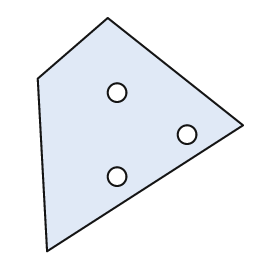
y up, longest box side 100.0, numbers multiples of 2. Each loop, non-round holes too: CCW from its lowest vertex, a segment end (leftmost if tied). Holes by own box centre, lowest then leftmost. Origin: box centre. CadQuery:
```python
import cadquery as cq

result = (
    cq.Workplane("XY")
    .moveTo(-40.0, -50.0)
    .lineTo(44.0, 4.0)
    .lineTo(-14.0, 50.0)
    .lineTo(-44.0, 24.0)
    .close()
    .moveTo(-10.0, -18.0)
    .circle(4.0)
    .moveTo(20.0, 0.0)
    .circle(4.0)
    .moveTo(-10.0, 18.0)
    .circle(4.0)
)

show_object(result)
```